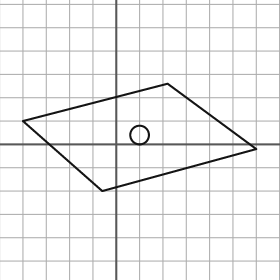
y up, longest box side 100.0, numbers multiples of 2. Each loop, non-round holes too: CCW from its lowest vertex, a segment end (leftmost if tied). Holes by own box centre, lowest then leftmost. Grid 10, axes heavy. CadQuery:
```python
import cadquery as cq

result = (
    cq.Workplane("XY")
    .moveTo(-6.0, -20.0)
    .lineTo(60.0, -2.0)
    .lineTo(22.0, 26.0)
    .lineTo(-40.0, 10.0)
    .close()
    .moveTo(10.0, 4.0)
    .circle(4.0)
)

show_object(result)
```